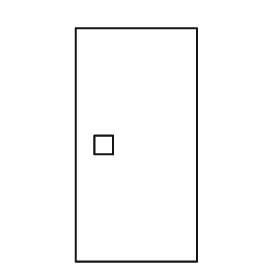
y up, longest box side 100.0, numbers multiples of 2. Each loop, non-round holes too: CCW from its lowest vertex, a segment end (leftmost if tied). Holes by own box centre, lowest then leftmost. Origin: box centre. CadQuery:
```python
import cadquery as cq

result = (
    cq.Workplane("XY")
    .moveTo(-26.0, -50.0)
    .lineTo(26.0, -50.0)
    .lineTo(26.0, 50.0)
    .lineTo(-26.0, 50.0)
    .close()
    .moveTo(-18.0, -4.0)
    .lineTo(-10.0, -4.0)
    .lineTo(-10.0, 4.0)
    .lineTo(-18.0, 4.0)
    .close()
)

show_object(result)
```